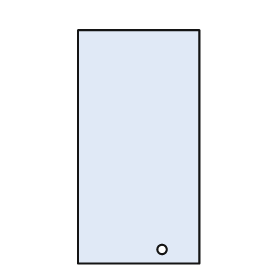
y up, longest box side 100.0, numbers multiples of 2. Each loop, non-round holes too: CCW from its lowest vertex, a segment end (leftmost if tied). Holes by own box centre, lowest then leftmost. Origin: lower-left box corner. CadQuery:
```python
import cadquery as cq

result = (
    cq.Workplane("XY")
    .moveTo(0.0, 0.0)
    .lineTo(52.0, 0.0)
    .lineTo(52.0, 100.0)
    .lineTo(0.0, 100.0)
    .close()
    .moveTo(36.0, 6.0)
    .circle(2.0)
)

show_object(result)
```